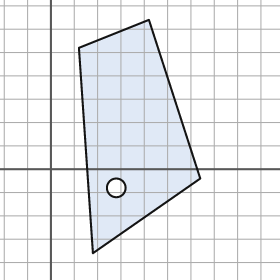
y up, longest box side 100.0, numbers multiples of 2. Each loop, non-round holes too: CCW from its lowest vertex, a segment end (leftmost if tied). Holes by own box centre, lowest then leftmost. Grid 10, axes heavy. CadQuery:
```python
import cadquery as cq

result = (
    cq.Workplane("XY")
    .moveTo(18.0, -36.0)
    .lineTo(64.0, -4.0)
    .lineTo(42.0, 64.0)
    .lineTo(12.0, 52.0)
    .close()
    .moveTo(28.0, -8.0)
    .circle(4.0)
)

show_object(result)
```